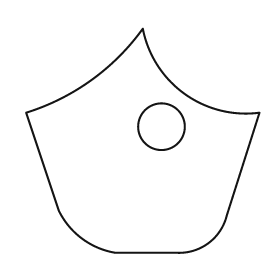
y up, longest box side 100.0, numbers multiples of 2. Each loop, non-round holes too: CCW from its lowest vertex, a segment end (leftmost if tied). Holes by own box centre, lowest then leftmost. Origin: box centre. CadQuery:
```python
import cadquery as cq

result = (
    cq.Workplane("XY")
    .moveTo(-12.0, -48.0)
    .lineTo(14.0, -48.0)
    .threePointArc((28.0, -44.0), (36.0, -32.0))
    .lineTo(50.0, 12.0)
    .threePointArc((18.0, 20.0), (0.0, 48.0))
    .threePointArc((-22.0, 26.0), (-50.0, 12.0))
    .lineTo(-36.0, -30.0)
    .threePointArc((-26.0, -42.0), (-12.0, -48.0))
    .close()
    .moveTo(8.0, 6.0)
    .circle(10.0)
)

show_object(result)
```